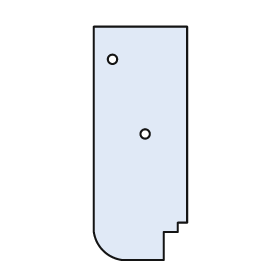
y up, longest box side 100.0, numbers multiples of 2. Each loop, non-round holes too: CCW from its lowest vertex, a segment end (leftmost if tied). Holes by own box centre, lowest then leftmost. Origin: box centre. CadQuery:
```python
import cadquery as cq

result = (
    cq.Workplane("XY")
    .moveTo(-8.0, -50.0)
    .lineTo(10.0, -50.0)
    .lineTo(10.0, -38.0)
    .lineTo(16.0, -38.0)
    .lineTo(16.0, -34.0)
    .lineTo(20.0, -34.0)
    .lineTo(20.0, 50.0)
    .lineTo(-20.0, 50.0)
    .lineTo(-20.0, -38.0)
    .threePointArc((-16.0, -46.0), (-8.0, -50.0))
    .close()
    .moveTo(2.0, 4.0)
    .circle(2.0)
    .moveTo(-12.0, 36.0)
    .circle(2.0)
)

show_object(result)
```